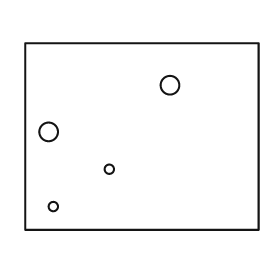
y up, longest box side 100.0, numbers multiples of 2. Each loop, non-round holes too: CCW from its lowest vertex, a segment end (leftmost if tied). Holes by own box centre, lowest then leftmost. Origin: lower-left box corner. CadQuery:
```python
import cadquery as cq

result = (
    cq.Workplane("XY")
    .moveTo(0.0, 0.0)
    .lineTo(100.0, 0.0)
    .lineTo(100.0, 80.0)
    .lineTo(0.0, 80.0)
    .close()
    .moveTo(12.0, 10.0)
    .circle(2.0)
    .moveTo(36.0, 26.0)
    .circle(2.0)
    .moveTo(10.0, 42.0)
    .circle(4.0)
    .moveTo(62.0, 62.0)
    .circle(4.0)
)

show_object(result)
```